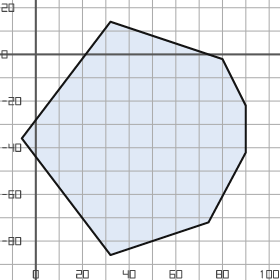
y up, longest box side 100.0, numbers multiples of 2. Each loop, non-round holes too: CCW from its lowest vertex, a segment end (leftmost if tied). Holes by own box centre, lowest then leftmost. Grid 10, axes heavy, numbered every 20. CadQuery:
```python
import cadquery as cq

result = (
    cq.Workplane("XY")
    .moveTo(32.0, -86.0)
    .lineTo(74.0, -72.0)
    .lineTo(90.0, -42.0)
    .lineTo(90.0, -22.0)
    .lineTo(80.0, -2.0)
    .lineTo(32.0, 14.0)
    .lineTo(-6.0, -36.0)
    .close()
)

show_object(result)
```